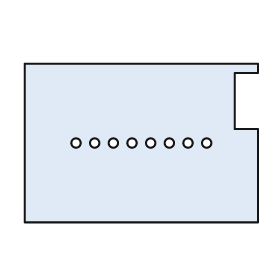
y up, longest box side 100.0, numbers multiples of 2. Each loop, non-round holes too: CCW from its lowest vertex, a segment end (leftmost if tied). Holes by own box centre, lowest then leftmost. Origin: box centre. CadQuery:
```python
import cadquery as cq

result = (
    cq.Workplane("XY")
    .moveTo(-50.0, -34.0)
    .lineTo(50.0, -34.0)
    .lineTo(50.0, 6.0)
    .lineTo(40.0, 6.0)
    .lineTo(40.0, 30.0)
    .lineTo(50.0, 30.0)
    .lineTo(50.0, 34.0)
    .lineTo(-50.0, 34.0)
    .close()
    .moveTo(-28.0, 0.0)
    .circle(2.0)
    .moveTo(-20.0, 0.0)
    .circle(2.0)
    .moveTo(-12.0, 0.0)
    .circle(2.0)
    .moveTo(-4.0, 0.0)
    .circle(2.0)
    .moveTo(4.0, 0.0)
    .circle(2.0)
    .moveTo(12.0, 0.0)
    .circle(2.0)
    .moveTo(20.0, 0.0)
    .circle(2.0)
    .moveTo(28.0, 0.0)
    .circle(2.0)
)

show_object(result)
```